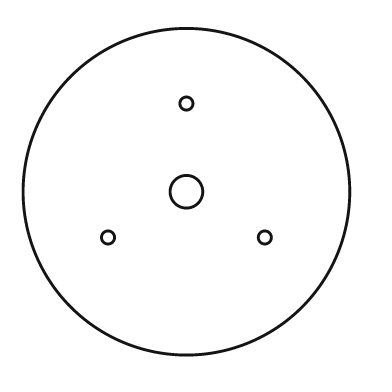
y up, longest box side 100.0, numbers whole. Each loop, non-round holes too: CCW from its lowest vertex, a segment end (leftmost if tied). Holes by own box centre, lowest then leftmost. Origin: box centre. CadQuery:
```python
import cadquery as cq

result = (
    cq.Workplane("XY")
    .moveTo(0.0, 0.0)
    .circle(50.0)
    .moveTo(-24.0, -14.0)
    .circle(2.0)
    .moveTo(24.0, -14.0)
    .circle(2.0)
    .moveTo(0.0, 0.0)
    .circle(5.0)
    .moveTo(0.0, 27.0)
    .circle(2.0)
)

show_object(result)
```